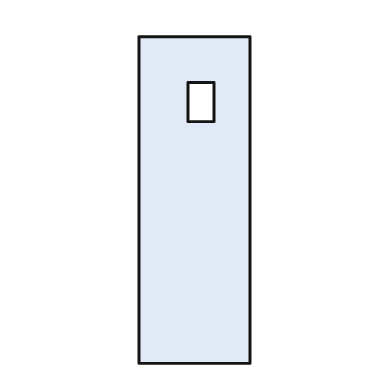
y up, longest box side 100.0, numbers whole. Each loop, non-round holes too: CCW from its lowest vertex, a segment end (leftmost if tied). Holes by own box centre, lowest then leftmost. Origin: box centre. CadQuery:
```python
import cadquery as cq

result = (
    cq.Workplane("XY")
    .moveTo(-17.0, -50.0)
    .lineTo(17.0, -50.0)
    .lineTo(17.0, 50.0)
    .lineTo(-17.0, 50.0)
    .close()
    .moveTo(-2.0, 24.0)
    .lineTo(6.0, 24.0)
    .lineTo(6.0, 36.0)
    .lineTo(-2.0, 36.0)
    .close()
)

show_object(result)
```